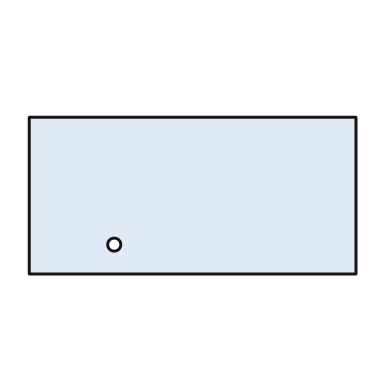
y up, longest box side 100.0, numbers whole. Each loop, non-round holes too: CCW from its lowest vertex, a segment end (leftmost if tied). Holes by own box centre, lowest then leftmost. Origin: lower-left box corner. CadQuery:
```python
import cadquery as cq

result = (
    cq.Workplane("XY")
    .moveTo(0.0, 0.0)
    .lineTo(100.0, 0.0)
    .lineTo(100.0, 48.0)
    .lineTo(0.0, 48.0)
    .close()
    .moveTo(26.0, 9.0)
    .circle(2.0)
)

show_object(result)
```